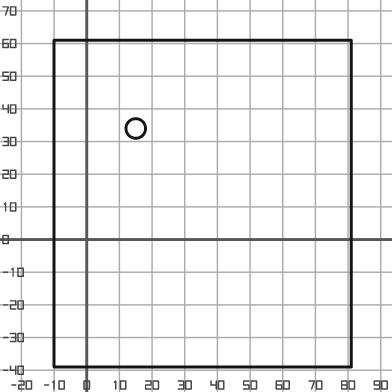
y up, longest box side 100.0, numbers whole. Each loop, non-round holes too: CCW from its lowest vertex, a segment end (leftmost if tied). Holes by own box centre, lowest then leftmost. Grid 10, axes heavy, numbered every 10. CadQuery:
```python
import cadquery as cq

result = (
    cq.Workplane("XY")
    .moveTo(-10.0, -39.0)
    .lineTo(81.0, -39.0)
    .lineTo(81.0, 61.0)
    .lineTo(-10.0, 61.0)
    .close()
    .moveTo(15.0, 34.0)
    .circle(3.0)
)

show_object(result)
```